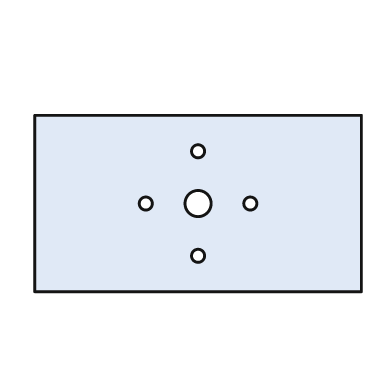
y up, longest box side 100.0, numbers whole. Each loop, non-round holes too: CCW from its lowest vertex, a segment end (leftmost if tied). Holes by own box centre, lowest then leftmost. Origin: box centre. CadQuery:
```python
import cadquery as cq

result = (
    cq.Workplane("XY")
    .moveTo(-50.0, -27.0)
    .lineTo(50.0, -27.0)
    .lineTo(50.0, 27.0)
    .lineTo(-50.0, 27.0)
    .close()
    .moveTo(0.0, -16.0)
    .circle(2.0)
    .moveTo(-16.0, 0.0)
    .circle(2.0)
    .moveTo(0.0, 0.0)
    .circle(4.0)
    .moveTo(16.0, 0.0)
    .circle(2.0)
    .moveTo(0.0, 16.0)
    .circle(2.0)
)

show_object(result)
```